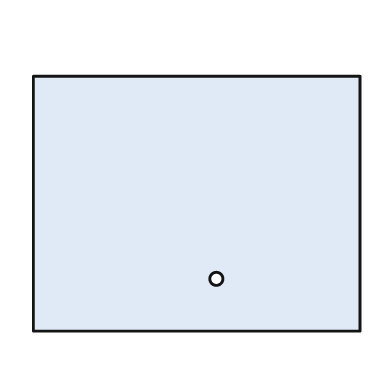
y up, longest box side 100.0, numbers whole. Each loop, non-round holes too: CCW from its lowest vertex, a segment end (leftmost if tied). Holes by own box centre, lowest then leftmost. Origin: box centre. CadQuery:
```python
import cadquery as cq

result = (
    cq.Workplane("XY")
    .moveTo(-50.0, -39.0)
    .lineTo(50.0, -39.0)
    .lineTo(50.0, 39.0)
    .lineTo(-50.0, 39.0)
    .close()
    .moveTo(6.0, -23.0)
    .circle(2.0)
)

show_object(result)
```